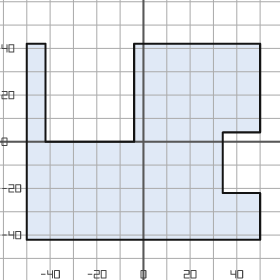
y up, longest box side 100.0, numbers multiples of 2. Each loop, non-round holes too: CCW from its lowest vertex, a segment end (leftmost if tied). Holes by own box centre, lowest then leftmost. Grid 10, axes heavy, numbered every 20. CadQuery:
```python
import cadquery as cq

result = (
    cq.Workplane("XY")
    .moveTo(-50.0, -42.0)
    .lineTo(50.0, -42.0)
    .lineTo(50.0, -22.0)
    .lineTo(34.0, -22.0)
    .lineTo(34.0, 4.0)
    .lineTo(50.0, 4.0)
    .lineTo(50.0, 42.0)
    .lineTo(-4.0, 42.0)
    .lineTo(-4.0, 0.0)
    .lineTo(-42.0, 0.0)
    .lineTo(-42.0, 42.0)
    .lineTo(-50.0, 42.0)
    .close()
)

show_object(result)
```